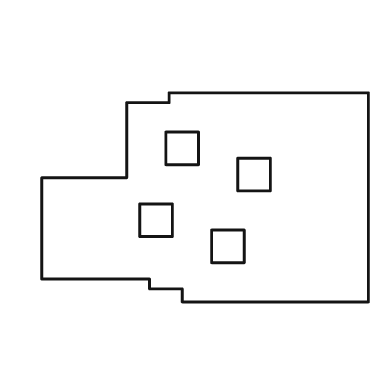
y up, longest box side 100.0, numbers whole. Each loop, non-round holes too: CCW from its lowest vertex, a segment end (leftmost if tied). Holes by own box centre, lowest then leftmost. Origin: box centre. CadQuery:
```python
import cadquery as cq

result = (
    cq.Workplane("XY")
    .moveTo(-7.0, -32.0)
    .lineTo(50.0, -32.0)
    .lineTo(50.0, 32.0)
    .lineTo(-11.0, 32.0)
    .lineTo(-11.0, 29.0)
    .lineTo(-24.0, 29.0)
    .lineTo(-24.0, 6.0)
    .lineTo(-50.0, 6.0)
    .lineTo(-50.0, -25.0)
    .lineTo(-17.0, -25.0)
    .lineTo(-17.0, -28.0)
    .lineTo(-7.0, -28.0)
    .close()
    .moveTo(2.0, -20.0)
    .lineTo(12.0, -20.0)
    .lineTo(12.0, -10.0)
    .lineTo(2.0, -10.0)
    .close()
    .moveTo(-20.0, -12.0)
    .lineTo(-10.0, -12.0)
    .lineTo(-10.0, -2.0)
    .lineTo(-20.0, -2.0)
    .close()
    .moveTo(10.0, 2.0)
    .lineTo(20.0, 2.0)
    .lineTo(20.0, 12.0)
    .lineTo(10.0, 12.0)
    .close()
    .moveTo(-12.0, 10.0)
    .lineTo(-2.0, 10.0)
    .lineTo(-2.0, 20.0)
    .lineTo(-12.0, 20.0)
    .close()
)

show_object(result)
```